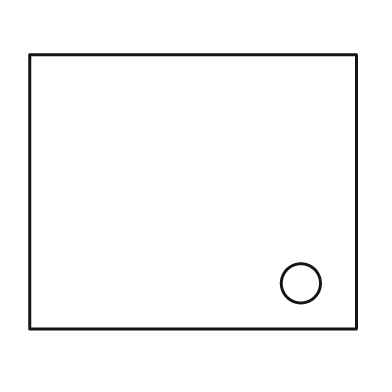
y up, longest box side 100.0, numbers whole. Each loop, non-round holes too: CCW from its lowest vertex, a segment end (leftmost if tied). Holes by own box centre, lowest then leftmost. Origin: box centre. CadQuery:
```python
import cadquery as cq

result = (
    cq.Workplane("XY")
    .moveTo(-50.0, -42.0)
    .lineTo(50.0, -42.0)
    .lineTo(50.0, 42.0)
    .lineTo(-50.0, 42.0)
    .close()
    .moveTo(33.0, -28.0)
    .circle(6.0)
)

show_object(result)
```